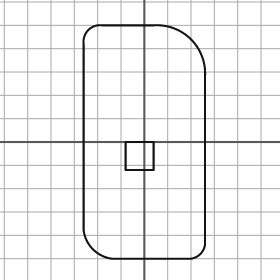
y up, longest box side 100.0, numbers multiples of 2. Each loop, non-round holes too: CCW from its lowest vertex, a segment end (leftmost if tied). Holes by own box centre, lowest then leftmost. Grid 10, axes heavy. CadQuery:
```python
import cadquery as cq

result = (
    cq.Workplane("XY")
    .moveTo(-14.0, -50.0)
    .lineTo(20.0, -50.0)
    .threePointArc((24.0, -48.0), (26.0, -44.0))
    .lineTo(26.0, 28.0)
    .threePointArc((20.0, 44.0), (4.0, 50.0))
    .lineTo(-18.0, 50.0)
    .threePointArc((-24.0, 48.0), (-26.0, 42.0))
    .lineTo(-26.0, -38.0)
    .threePointArc((-22.0, -46.0), (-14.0, -50.0))
    .close()
    .moveTo(-8.0, -12.0)
    .lineTo(4.0, -12.0)
    .lineTo(4.0, 0.0)
    .lineTo(-8.0, 0.0)
    .close()
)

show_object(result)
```